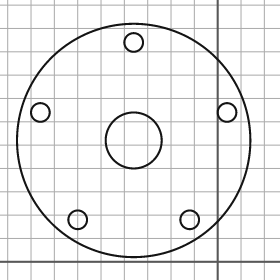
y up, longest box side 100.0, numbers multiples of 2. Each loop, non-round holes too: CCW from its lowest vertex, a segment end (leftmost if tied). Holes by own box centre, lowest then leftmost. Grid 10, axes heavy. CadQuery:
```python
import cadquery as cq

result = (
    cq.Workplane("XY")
    .moveTo(-36.0, 52.0)
    .circle(50.0)
    .moveTo(-60.0, 18.0)
    .circle(4.0)
    .moveTo(-12.0, 18.0)
    .circle(4.0)
    .moveTo(-36.0, 52.0)
    .circle(12.0)
    .moveTo(-76.0, 64.0)
    .circle(4.0)
    .moveTo(4.0, 64.0)
    .circle(4.0)
    .moveTo(-36.0, 94.0)
    .circle(4.0)
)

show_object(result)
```